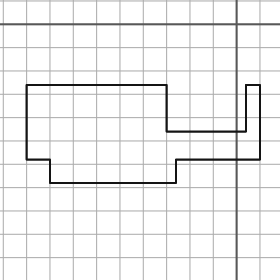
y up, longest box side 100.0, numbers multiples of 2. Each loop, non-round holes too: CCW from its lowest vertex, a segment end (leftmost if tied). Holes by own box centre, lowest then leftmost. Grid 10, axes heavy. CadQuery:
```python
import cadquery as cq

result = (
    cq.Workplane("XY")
    .moveTo(-80.0, -68.0)
    .lineTo(-26.0, -68.0)
    .lineTo(-26.0, -58.0)
    .lineTo(10.0, -58.0)
    .lineTo(10.0, -26.0)
    .lineTo(4.0, -26.0)
    .lineTo(4.0, -46.0)
    .lineTo(-30.0, -46.0)
    .lineTo(-30.0, -26.0)
    .lineTo(-90.0, -26.0)
    .lineTo(-90.0, -58.0)
    .lineTo(-80.0, -58.0)
    .close()
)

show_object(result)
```